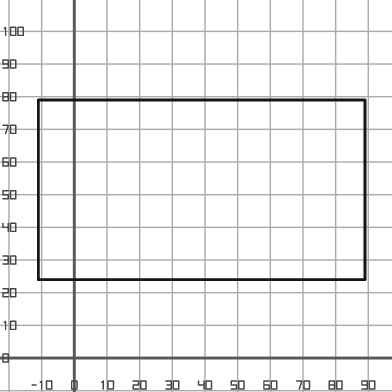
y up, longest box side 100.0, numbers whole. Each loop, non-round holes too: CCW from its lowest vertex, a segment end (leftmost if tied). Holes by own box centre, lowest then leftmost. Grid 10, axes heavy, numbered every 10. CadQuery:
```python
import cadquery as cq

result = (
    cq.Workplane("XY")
    .moveTo(-11.0, 24.0)
    .lineTo(89.0, 24.0)
    .lineTo(89.0, 79.0)
    .lineTo(-11.0, 79.0)
    .close()
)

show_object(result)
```